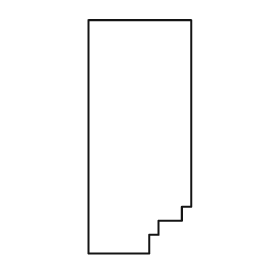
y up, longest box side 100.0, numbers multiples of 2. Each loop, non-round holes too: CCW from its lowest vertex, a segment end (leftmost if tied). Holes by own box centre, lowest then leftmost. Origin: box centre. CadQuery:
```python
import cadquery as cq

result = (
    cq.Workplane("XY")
    .moveTo(-22.0, -50.0)
    .lineTo(4.0, -50.0)
    .lineTo(4.0, -42.0)
    .lineTo(8.0, -42.0)
    .lineTo(8.0, -36.0)
    .lineTo(18.0, -36.0)
    .lineTo(18.0, -30.0)
    .lineTo(22.0, -30.0)
    .lineTo(22.0, 50.0)
    .lineTo(-22.0, 50.0)
    .close()
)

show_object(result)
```